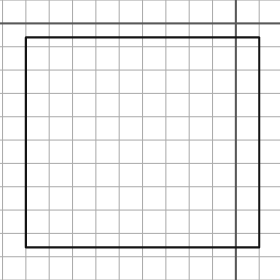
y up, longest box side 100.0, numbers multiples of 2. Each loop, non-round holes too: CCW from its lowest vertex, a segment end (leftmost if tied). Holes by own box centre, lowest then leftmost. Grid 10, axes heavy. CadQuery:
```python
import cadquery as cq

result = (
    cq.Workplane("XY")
    .moveTo(-90.0, -96.0)
    .lineTo(10.0, -96.0)
    .lineTo(10.0, -6.0)
    .lineTo(-90.0, -6.0)
    .close()
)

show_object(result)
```